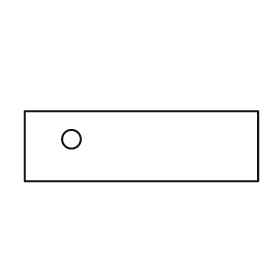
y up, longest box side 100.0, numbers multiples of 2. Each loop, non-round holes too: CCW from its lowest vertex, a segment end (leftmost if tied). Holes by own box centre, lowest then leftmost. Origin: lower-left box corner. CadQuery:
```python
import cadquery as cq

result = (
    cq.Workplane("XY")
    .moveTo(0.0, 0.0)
    .lineTo(100.0, 0.0)
    .lineTo(100.0, 30.0)
    .lineTo(0.0, 30.0)
    .close()
    .moveTo(20.0, 18.0)
    .circle(4.0)
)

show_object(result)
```